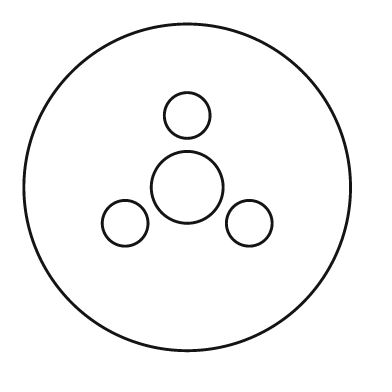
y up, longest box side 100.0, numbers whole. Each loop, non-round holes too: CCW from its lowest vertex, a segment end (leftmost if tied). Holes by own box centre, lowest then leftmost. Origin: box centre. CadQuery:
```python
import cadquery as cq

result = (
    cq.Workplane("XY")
    .moveTo(0.0, 0.0)
    .circle(50.0)
    .moveTo(-19.0, -11.0)
    .circle(7.0)
    .moveTo(19.0, -11.0)
    .circle(7.0)
    .moveTo(0.0, 0.0)
    .circle(11.0)
    .moveTo(0.0, 22.0)
    .circle(7.0)
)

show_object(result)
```